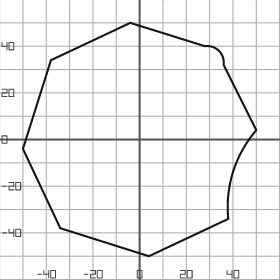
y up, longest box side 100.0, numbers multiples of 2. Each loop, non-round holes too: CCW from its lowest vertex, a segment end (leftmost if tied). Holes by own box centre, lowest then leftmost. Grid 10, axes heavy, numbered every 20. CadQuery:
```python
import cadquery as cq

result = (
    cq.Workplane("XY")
    .moveTo(4.0, -50.0)
    .lineTo(38.0, -34.0)
    .threePointArc((40.0, -14.0), (50.0, 4.0))
    .lineTo(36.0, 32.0)
    .threePointArc((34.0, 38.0), (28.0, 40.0))
    .lineTo(-4.0, 50.0)
    .lineTo(-38.0, 34.0)
    .lineTo(-50.0, -4.0)
    .lineTo(-34.0, -38.0)
    .close()
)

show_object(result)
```